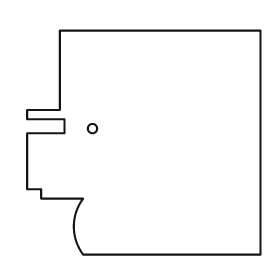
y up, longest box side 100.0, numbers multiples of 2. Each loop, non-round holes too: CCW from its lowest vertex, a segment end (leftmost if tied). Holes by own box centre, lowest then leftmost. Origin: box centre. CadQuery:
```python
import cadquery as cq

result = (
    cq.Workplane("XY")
    .moveTo(-26.0, -48.0)
    .lineTo(50.0, -48.0)
    .lineTo(50.0, 48.0)
    .lineTo(-36.0, 48.0)
    .lineTo(-36.0, 14.0)
    .lineTo(-50.0, 14.0)
    .lineTo(-50.0, 10.0)
    .lineTo(-34.0, 10.0)
    .lineTo(-34.0, 4.0)
    .lineTo(-50.0, 4.0)
    .lineTo(-50.0, -20.0)
    .lineTo(-44.0, -20.0)
    .lineTo(-44.0, -24.0)
    .lineTo(-26.0, -24.0)
    .threePointArc((-30.0, -36.0), (-26.0, -48.0))
    .close()
    .moveTo(-22.0, 6.0)
    .circle(2.0)
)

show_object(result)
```